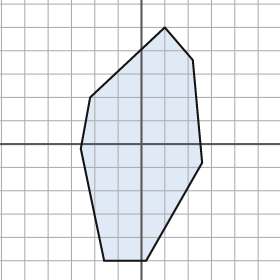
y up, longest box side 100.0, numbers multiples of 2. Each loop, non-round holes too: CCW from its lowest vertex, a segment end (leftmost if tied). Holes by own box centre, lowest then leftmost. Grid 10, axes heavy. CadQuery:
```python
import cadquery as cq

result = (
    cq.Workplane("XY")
    .moveTo(-16.0, -50.0)
    .lineTo(2.0, -50.0)
    .lineTo(26.0, -8.0)
    .lineTo(22.0, 36.0)
    .lineTo(10.0, 50.0)
    .lineTo(-22.0, 20.0)
    .lineTo(-26.0, -2.0)
    .close()
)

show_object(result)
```